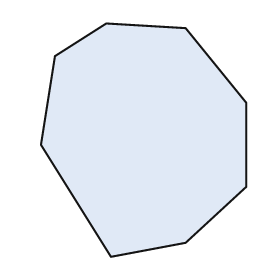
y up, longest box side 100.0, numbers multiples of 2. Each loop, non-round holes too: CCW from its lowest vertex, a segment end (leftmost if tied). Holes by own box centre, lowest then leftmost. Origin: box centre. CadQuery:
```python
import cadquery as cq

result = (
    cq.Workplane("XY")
    .moveTo(-14.0, -50.0)
    .lineTo(18.0, -44.0)
    .lineTo(44.0, -20.0)
    .lineTo(44.0, 16.0)
    .lineTo(18.0, 48.0)
    .lineTo(-16.0, 50.0)
    .lineTo(-38.0, 36.0)
    .lineTo(-44.0, -2.0)
    .close()
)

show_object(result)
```